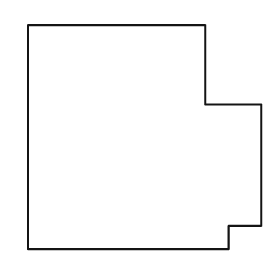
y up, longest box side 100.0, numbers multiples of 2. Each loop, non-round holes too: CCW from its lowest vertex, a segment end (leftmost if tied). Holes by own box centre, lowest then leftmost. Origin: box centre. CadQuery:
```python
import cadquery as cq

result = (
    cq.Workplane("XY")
    .moveTo(-50.0, -48.0)
    .lineTo(36.0, -48.0)
    .lineTo(36.0, -38.0)
    .lineTo(50.0, -38.0)
    .lineTo(50.0, 14.0)
    .lineTo(26.0, 14.0)
    .lineTo(26.0, 48.0)
    .lineTo(-50.0, 48.0)
    .close()
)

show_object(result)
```